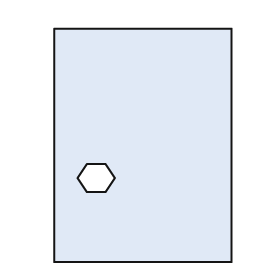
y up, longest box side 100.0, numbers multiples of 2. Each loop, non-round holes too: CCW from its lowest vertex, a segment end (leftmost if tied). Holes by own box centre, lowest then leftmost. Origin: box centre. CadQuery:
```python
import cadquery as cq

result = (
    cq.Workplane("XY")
    .moveTo(-38.0, -50.0)
    .lineTo(38.0, -50.0)
    .lineTo(38.0, 50.0)
    .lineTo(-38.0, 50.0)
    .close()
    .moveTo(-24.0, -20.0)
    .lineTo(-16.0, -20.0)
    .lineTo(-12.0, -14.0)
    .lineTo(-16.0, -8.0)
    .lineTo(-24.0, -8.0)
    .lineTo(-28.0, -14.0)
    .close()
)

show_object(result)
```